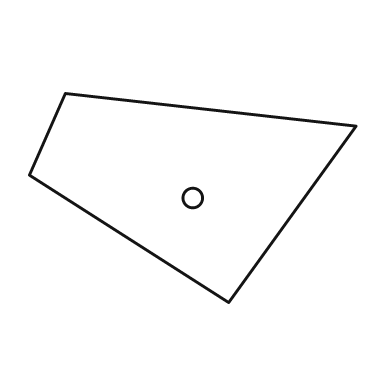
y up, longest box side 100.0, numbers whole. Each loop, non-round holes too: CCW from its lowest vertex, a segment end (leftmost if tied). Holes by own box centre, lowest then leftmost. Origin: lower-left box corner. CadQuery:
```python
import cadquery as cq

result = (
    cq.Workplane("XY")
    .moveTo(61.0, 0.0)
    .lineTo(100.0, 54.0)
    .lineTo(11.0, 64.0)
    .lineTo(0.0, 39.0)
    .close()
    .moveTo(50.0, 32.0)
    .circle(3.0)
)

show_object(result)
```